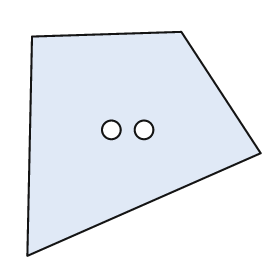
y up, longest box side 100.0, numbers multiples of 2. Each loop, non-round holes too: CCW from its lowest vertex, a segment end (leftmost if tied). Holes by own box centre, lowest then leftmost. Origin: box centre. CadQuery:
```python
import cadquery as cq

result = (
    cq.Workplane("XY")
    .moveTo(-50.0, -48.0)
    .lineTo(50.0, -4.0)
    .lineTo(16.0, 48.0)
    .lineTo(-48.0, 46.0)
    .close()
    .moveTo(-14.0, 6.0)
    .circle(4.0)
    .moveTo(0.0, 6.0)
    .circle(4.0)
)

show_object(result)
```